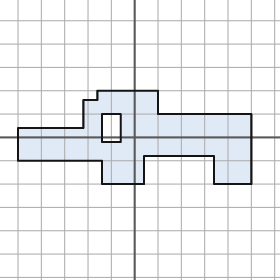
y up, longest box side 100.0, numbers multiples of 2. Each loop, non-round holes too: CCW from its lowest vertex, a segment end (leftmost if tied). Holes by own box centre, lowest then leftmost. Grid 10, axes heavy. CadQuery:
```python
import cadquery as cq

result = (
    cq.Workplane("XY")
    .moveTo(-14.0, -20.0)
    .lineTo(4.0, -20.0)
    .lineTo(4.0, -8.0)
    .lineTo(34.0, -8.0)
    .lineTo(34.0, -20.0)
    .lineTo(50.0, -20.0)
    .lineTo(50.0, 10.0)
    .lineTo(10.0, 10.0)
    .lineTo(10.0, 20.0)
    .lineTo(-16.0, 20.0)
    .lineTo(-16.0, 16.0)
    .lineTo(-22.0, 16.0)
    .lineTo(-22.0, 4.0)
    .lineTo(-50.0, 4.0)
    .lineTo(-50.0, -10.0)
    .lineTo(-14.0, -10.0)
    .close()
    .moveTo(-14.0, -2.0)
    .lineTo(-6.0, -2.0)
    .lineTo(-6.0, 10.0)
    .lineTo(-14.0, 10.0)
    .close()
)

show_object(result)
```